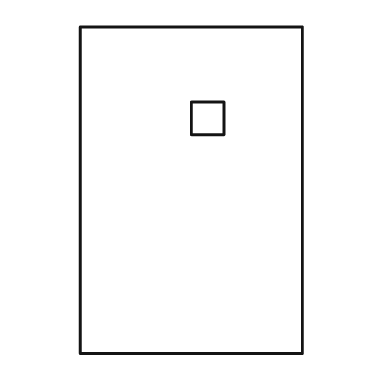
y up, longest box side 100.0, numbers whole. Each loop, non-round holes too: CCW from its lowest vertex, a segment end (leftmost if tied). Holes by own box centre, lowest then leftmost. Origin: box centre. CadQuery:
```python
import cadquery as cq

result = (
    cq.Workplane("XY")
    .moveTo(-34.0, -50.0)
    .lineTo(34.0, -50.0)
    .lineTo(34.0, 50.0)
    .lineTo(-34.0, 50.0)
    .close()
    .moveTo(0.0, 17.0)
    .lineTo(10.0, 17.0)
    .lineTo(10.0, 27.0)
    .lineTo(0.0, 27.0)
    .close()
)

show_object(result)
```